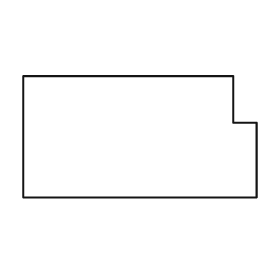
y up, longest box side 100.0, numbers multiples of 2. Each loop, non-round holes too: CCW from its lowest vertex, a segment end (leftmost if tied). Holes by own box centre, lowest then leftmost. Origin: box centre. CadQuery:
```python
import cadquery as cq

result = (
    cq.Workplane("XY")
    .moveTo(-50.0, -26.0)
    .lineTo(50.0, -26.0)
    .lineTo(50.0, 6.0)
    .lineTo(40.0, 6.0)
    .lineTo(40.0, 26.0)
    .lineTo(-50.0, 26.0)
    .close()
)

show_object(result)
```